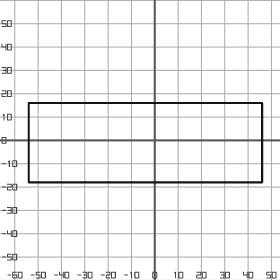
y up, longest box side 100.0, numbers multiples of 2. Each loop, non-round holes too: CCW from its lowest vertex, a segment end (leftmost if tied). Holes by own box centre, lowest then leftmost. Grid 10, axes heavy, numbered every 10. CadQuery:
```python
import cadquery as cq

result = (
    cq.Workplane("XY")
    .moveTo(-54.0, -18.0)
    .lineTo(46.0, -18.0)
    .lineTo(46.0, 16.0)
    .lineTo(-54.0, 16.0)
    .close()
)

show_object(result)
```